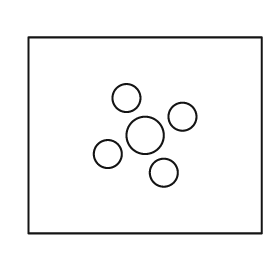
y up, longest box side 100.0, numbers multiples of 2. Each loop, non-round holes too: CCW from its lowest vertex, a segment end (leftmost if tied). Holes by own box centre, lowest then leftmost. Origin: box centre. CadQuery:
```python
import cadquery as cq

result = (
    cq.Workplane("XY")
    .moveTo(-50.0, -42.0)
    .lineTo(50.0, -42.0)
    .lineTo(50.0, 42.0)
    .lineTo(-50.0, 42.0)
    .close()
    .moveTo(8.0, -16.0)
    .circle(6.0)
    .moveTo(-16.0, -8.0)
    .circle(6.0)
    .moveTo(0.0, 0.0)
    .circle(8.0)
    .moveTo(16.0, 8.0)
    .circle(6.0)
    .moveTo(-8.0, 16.0)
    .circle(6.0)
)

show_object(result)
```